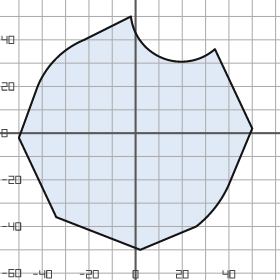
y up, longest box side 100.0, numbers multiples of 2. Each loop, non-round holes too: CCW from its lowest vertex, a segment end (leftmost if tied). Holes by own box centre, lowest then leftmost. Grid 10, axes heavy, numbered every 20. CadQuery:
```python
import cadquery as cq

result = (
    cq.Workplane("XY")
    .moveTo(2.0, -50.0)
    .lineTo(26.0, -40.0)
    .threePointArc((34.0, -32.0), (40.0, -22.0))
    .lineTo(50.0, 2.0)
    .lineTo(34.0, 36.0)
    .threePointArc((12.0, 32.0), (-2.0, 50.0))
    .lineTo(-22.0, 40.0)
    .threePointArc((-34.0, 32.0), (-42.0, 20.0))
    .lineTo(-50.0, -2.0)
    .lineTo(-34.0, -36.0)
    .close()
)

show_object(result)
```